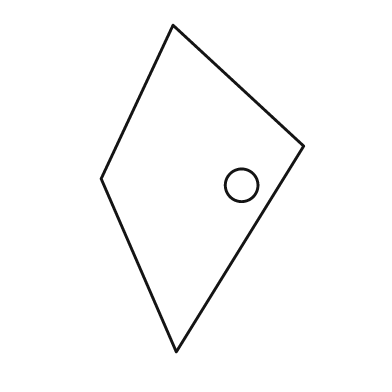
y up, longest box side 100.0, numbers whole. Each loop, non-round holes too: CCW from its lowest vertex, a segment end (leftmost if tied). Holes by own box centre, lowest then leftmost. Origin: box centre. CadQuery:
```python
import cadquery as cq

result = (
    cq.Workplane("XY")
    .moveTo(-8.0, -50.0)
    .lineTo(31.0, 13.0)
    .lineTo(-9.0, 50.0)
    .lineTo(-31.0, 3.0)
    .close()
    .moveTo(12.0, 1.0)
    .circle(5.0)
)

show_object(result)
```